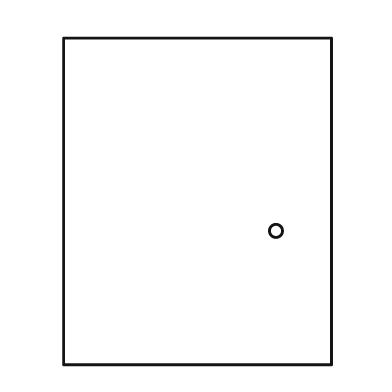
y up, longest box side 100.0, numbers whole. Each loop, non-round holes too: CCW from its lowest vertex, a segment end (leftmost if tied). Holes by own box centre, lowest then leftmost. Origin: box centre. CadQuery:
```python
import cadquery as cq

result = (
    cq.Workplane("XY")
    .moveTo(-41.0, -50.0)
    .lineTo(41.0, -50.0)
    .lineTo(41.0, 50.0)
    .lineTo(-41.0, 50.0)
    .close()
    .moveTo(24.0, -9.0)
    .circle(2.0)
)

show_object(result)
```